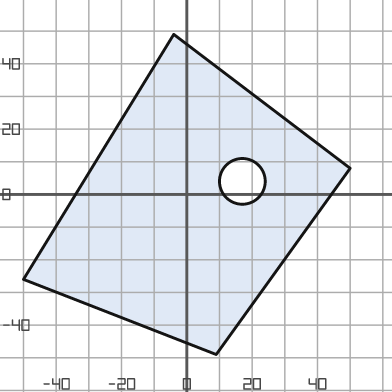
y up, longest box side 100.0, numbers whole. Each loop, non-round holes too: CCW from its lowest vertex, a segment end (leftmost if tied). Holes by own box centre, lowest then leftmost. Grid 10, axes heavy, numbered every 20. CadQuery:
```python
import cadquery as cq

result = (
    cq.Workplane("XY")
    .moveTo(9.0, -49.0)
    .lineTo(50.0, 8.0)
    .lineTo(-4.0, 49.0)
    .lineTo(-50.0, -26.0)
    .close()
    .moveTo(17.0, 4.0)
    .circle(7.0)
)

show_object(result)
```